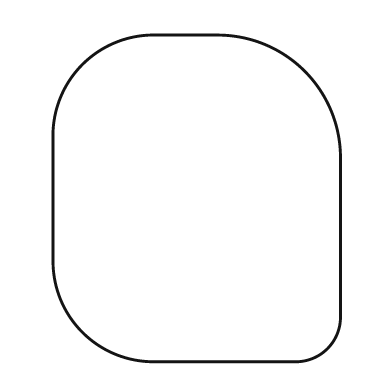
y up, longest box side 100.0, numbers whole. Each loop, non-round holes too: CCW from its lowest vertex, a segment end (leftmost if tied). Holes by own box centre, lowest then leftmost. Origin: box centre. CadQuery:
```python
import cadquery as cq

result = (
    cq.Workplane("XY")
    .moveTo(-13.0, -50.0)
    .lineTo(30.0, -50.0)
    .threePointArc((40.0, -46.0), (44.0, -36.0))
    .lineTo(44.0, 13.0)
    .threePointArc((33.0, 39.0), (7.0, 50.0))
    .lineTo(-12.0, 50.0)
    .threePointArc((-35.0, 41.0), (-44.0, 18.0))
    .lineTo(-44.0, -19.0)
    .threePointArc((-35.0, -41.0), (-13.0, -50.0))
    .close()
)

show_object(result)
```